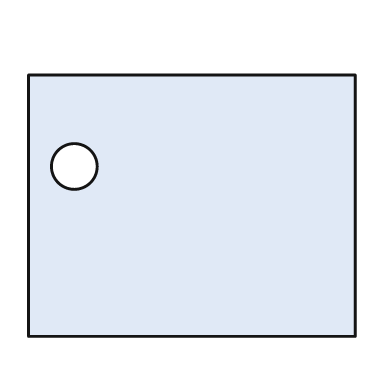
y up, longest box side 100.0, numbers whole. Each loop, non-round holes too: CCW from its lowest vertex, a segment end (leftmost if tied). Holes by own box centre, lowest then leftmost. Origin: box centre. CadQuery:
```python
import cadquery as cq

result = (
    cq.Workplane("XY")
    .moveTo(-50.0, -40.0)
    .lineTo(50.0, -40.0)
    .lineTo(50.0, 40.0)
    .lineTo(-50.0, 40.0)
    .close()
    .moveTo(-36.0, 12.0)
    .circle(7.0)
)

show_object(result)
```